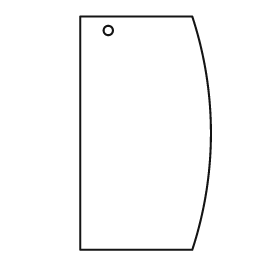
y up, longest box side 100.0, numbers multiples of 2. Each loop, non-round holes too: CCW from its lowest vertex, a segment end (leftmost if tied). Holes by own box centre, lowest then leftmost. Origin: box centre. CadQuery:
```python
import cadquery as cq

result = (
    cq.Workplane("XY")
    .moveTo(-28.0, -50.0)
    .lineTo(20.0, -50.0)
    .threePointArc((28.0, 0.0), (20.0, 50.0))
    .lineTo(-28.0, 50.0)
    .close()
    .moveTo(-16.0, 44.0)
    .circle(2.0)
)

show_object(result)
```